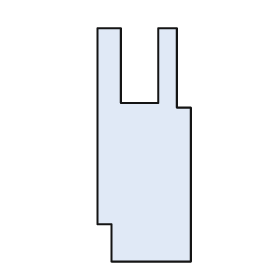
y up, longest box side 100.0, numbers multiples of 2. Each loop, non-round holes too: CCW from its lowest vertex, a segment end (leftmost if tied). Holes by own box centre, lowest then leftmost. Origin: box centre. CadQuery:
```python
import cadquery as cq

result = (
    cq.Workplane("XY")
    .moveTo(-14.0, -50.0)
    .lineTo(20.0, -50.0)
    .lineTo(20.0, 16.0)
    .lineTo(14.0, 16.0)
    .lineTo(14.0, 50.0)
    .lineTo(6.0, 50.0)
    .lineTo(6.0, 18.0)
    .lineTo(-10.0, 18.0)
    .lineTo(-10.0, 50.0)
    .lineTo(-20.0, 50.0)
    .lineTo(-20.0, -34.0)
    .lineTo(-14.0, -34.0)
    .close()
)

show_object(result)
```